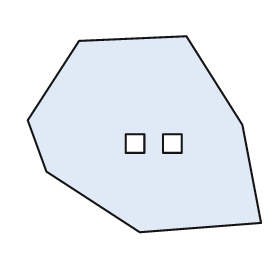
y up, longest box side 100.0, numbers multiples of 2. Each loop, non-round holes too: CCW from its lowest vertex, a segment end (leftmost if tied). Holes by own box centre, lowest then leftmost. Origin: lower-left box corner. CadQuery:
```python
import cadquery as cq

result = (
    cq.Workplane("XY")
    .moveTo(48.0, 0.0)
    .lineTo(100.0, 4.0)
    .lineTo(92.0, 46.0)
    .lineTo(68.0, 84.0)
    .lineTo(22.0, 82.0)
    .lineTo(0.0, 48.0)
    .lineTo(8.0, 26.0)
    .close()
    .moveTo(42.0, 34.0)
    .lineTo(50.0, 34.0)
    .lineTo(50.0, 42.0)
    .lineTo(42.0, 42.0)
    .close()
    .moveTo(58.0, 34.0)
    .lineTo(66.0, 34.0)
    .lineTo(66.0, 42.0)
    .lineTo(58.0, 42.0)
    .close()
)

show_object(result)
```